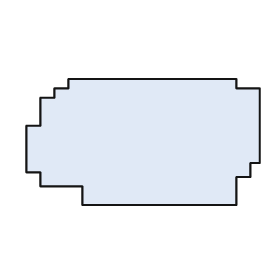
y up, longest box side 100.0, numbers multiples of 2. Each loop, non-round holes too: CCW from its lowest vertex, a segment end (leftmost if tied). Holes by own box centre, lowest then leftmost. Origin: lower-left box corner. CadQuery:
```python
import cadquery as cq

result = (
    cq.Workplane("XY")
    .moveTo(24.0, 0.0)
    .lineTo(90.0, 0.0)
    .lineTo(90.0, 12.0)
    .lineTo(96.0, 12.0)
    .lineTo(96.0, 18.0)
    .lineTo(100.0, 18.0)
    .lineTo(100.0, 50.0)
    .lineTo(90.0, 50.0)
    .lineTo(90.0, 54.0)
    .lineTo(18.0, 54.0)
    .lineTo(18.0, 50.0)
    .lineTo(12.0, 50.0)
    .lineTo(12.0, 46.0)
    .lineTo(6.0, 46.0)
    .lineTo(6.0, 34.0)
    .lineTo(0.0, 34.0)
    .lineTo(0.0, 14.0)
    .lineTo(6.0, 14.0)
    .lineTo(6.0, 8.0)
    .lineTo(24.0, 8.0)
    .close()
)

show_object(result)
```